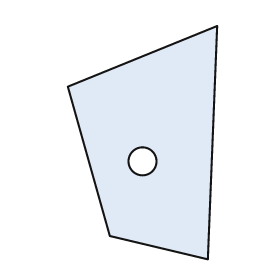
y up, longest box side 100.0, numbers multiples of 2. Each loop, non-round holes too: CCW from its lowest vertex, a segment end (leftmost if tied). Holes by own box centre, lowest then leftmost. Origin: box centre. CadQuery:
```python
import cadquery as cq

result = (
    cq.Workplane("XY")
    .moveTo(28.0, -50.0)
    .lineTo(32.0, 50.0)
    .lineTo(-32.0, 24.0)
    .lineTo(-14.0, -40.0)
    .close()
    .moveTo(0.0, -8.0)
    .circle(6.0)
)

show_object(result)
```